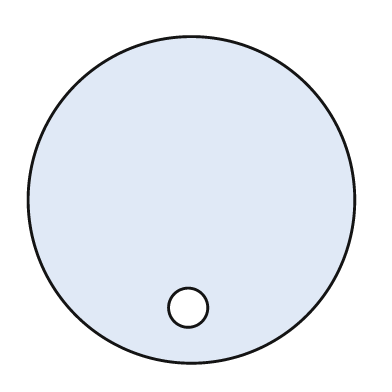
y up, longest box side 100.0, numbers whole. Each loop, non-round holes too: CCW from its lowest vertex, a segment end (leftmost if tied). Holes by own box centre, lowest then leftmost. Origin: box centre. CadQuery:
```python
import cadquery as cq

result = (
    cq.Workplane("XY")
    .moveTo(0.0, 0.0)
    .circle(50.0)
    .moveTo(-1.0, -33.0)
    .circle(6.0)
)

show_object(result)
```